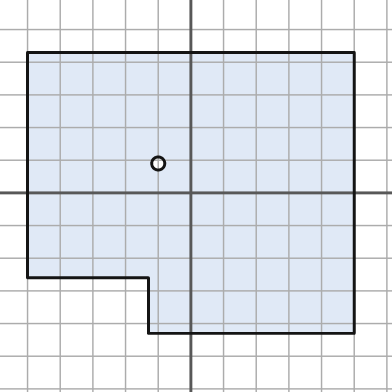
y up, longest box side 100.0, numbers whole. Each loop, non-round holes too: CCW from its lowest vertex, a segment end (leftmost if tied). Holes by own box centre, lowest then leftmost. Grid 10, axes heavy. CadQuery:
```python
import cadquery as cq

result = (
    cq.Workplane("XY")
    .moveTo(-13.0, -43.0)
    .lineTo(50.0, -43.0)
    .lineTo(50.0, 43.0)
    .lineTo(-50.0, 43.0)
    .lineTo(-50.0, -26.0)
    .lineTo(-13.0, -26.0)
    .close()
    .moveTo(-10.0, 9.0)
    .circle(2.0)
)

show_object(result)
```